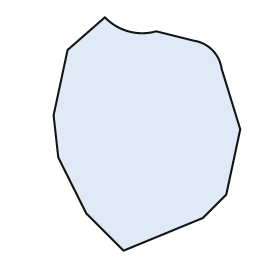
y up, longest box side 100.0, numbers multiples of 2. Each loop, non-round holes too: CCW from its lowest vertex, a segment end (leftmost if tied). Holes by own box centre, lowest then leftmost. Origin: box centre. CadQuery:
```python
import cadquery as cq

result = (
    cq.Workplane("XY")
    .moveTo(-10.0, -50.0)
    .lineTo(24.0, -36.0)
    .lineTo(34.0, -26.0)
    .lineTo(40.0, 2.0)
    .lineTo(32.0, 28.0)
    .threePointArc((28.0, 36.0), (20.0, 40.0))
    .lineTo(4.0, 44.0)
    .threePointArc((-8.0, 44.0), (-18.0, 50.0))
    .lineTo(-34.0, 36.0)
    .lineTo(-40.0, 8.0)
    .lineTo(-38.0, -10.0)
    .lineTo(-26.0, -34.0)
    .close()
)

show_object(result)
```